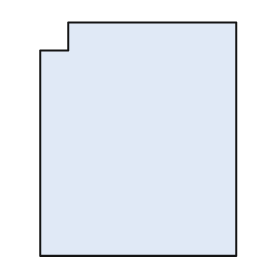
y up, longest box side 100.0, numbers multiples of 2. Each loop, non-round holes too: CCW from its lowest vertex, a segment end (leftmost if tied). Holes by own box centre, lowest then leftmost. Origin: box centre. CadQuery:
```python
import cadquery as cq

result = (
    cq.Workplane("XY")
    .moveTo(-42.0, -50.0)
    .lineTo(42.0, -50.0)
    .lineTo(42.0, 50.0)
    .lineTo(-30.0, 50.0)
    .lineTo(-30.0, 38.0)
    .lineTo(-42.0, 38.0)
    .close()
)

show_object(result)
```